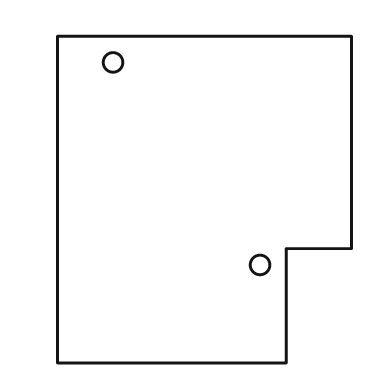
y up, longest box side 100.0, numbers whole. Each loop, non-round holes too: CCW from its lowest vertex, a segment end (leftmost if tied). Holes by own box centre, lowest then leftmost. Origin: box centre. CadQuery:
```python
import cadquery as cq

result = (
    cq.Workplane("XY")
    .moveTo(-45.0, -50.0)
    .lineTo(25.0, -50.0)
    .lineTo(25.0, -15.0)
    .lineTo(45.0, -15.0)
    .lineTo(45.0, 50.0)
    .lineTo(-45.0, 50.0)
    .close()
    .moveTo(17.0, -20.0)
    .circle(3.0)
    .moveTo(-28.0, 42.0)
    .circle(3.0)
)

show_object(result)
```